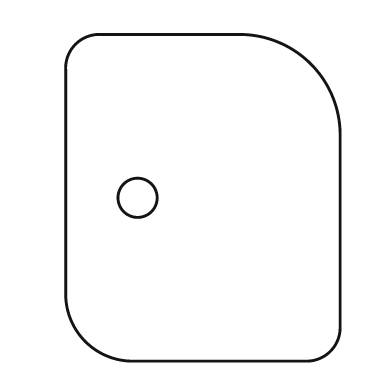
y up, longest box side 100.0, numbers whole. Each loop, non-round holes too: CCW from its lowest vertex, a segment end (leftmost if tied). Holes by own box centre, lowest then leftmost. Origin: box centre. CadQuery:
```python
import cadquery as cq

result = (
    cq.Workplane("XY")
    .moveTo(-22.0, -50.0)
    .lineTo(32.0, -50.0)
    .threePointArc((39.0, -47.0), (42.0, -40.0))
    .lineTo(42.0, 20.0)
    .threePointArc((33.0, 41.0), (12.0, 50.0))
    .lineTo(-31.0, 50.0)
    .threePointArc((-39.0, 47.0), (-42.0, 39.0))
    .lineTo(-42.0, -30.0)
    .threePointArc((-36.0, -44.0), (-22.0, -50.0))
    .close()
    .moveTo(-20.0, 0.0)
    .circle(6.0)
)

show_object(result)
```